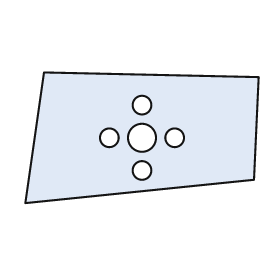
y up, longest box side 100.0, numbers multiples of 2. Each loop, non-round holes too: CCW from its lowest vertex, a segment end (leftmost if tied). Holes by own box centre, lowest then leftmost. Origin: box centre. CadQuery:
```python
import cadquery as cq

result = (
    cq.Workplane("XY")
    .moveTo(-50.0, -28.0)
    .lineTo(48.0, -18.0)
    .lineTo(50.0, 26.0)
    .lineTo(-42.0, 28.0)
    .close()
    .moveTo(0.0, -14.0)
    .circle(4.0)
    .moveTo(-14.0, 0.0)
    .circle(4.0)
    .moveTo(0.0, 0.0)
    .circle(6.0)
    .moveTo(14.0, 0.0)
    .circle(4.0)
    .moveTo(0.0, 14.0)
    .circle(4.0)
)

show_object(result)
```